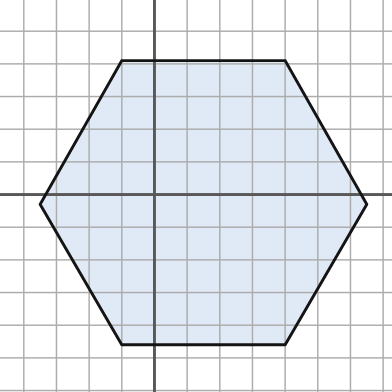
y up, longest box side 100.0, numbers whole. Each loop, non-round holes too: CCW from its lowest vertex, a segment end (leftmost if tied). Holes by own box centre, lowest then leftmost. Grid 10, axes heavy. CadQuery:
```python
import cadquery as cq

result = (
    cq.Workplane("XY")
    .moveTo(-10.0, -46.0)
    .lineTo(40.0, -46.0)
    .lineTo(65.0, -3.0)
    .lineTo(40.0, 41.0)
    .lineTo(-10.0, 41.0)
    .lineTo(-35.0, -3.0)
    .close()
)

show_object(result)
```